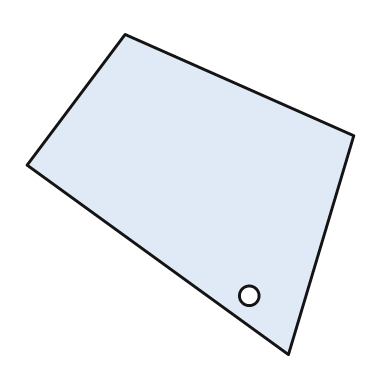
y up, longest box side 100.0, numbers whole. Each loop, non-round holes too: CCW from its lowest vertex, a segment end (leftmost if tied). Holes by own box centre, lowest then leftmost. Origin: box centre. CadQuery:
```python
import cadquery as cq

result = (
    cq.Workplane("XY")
    .moveTo(30.0, -49.0)
    .lineTo(50.0, 18.0)
    .lineTo(-20.0, 49.0)
    .lineTo(-50.0, 9.0)
    .close()
    .moveTo(18.0, -31.0)
    .circle(3.0)
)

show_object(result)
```